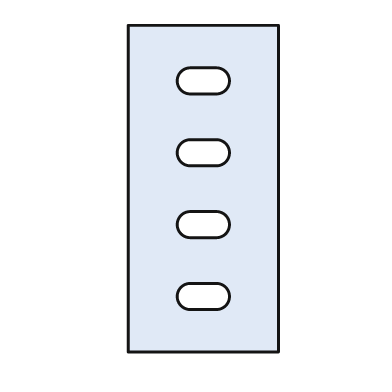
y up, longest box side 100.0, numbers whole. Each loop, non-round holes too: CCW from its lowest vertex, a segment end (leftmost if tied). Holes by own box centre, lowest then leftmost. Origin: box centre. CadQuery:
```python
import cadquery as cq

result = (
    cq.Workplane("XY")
    .moveTo(-23.0, -50.0)
    .lineTo(23.0, -50.0)
    .lineTo(23.0, 50.0)
    .lineTo(-23.0, 50.0)
    .close()
    .moveTo(-4.0, -37.0)
    .lineTo(4.0, -37.0)
    .threePointArc((8.0, -33.0), (4.0, -29.0))
    .lineTo(-4.0, -29.0)
    .threePointArc((-8.0, -33.0), (-4.0, -37.0))
    .close()
    .moveTo(-4.0, -15.0)
    .lineTo(4.0, -15.0)
    .threePointArc((8.0, -11.0), (4.0, -7.0))
    .lineTo(-4.0, -7.0)
    .threePointArc((-8.0, -11.0), (-4.0, -15.0))
    .close()
    .moveTo(-4.0, 7.0)
    .lineTo(4.0, 7.0)
    .threePointArc((8.0, 11.0), (4.0, 15.0))
    .lineTo(-4.0, 15.0)
    .threePointArc((-8.0, 11.0), (-4.0, 7.0))
    .close()
    .moveTo(-4.0, 29.0)
    .lineTo(4.0, 29.0)
    .threePointArc((8.0, 33.0), (4.0, 37.0))
    .lineTo(-4.0, 37.0)
    .threePointArc((-8.0, 33.0), (-4.0, 29.0))
    .close()
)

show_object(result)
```